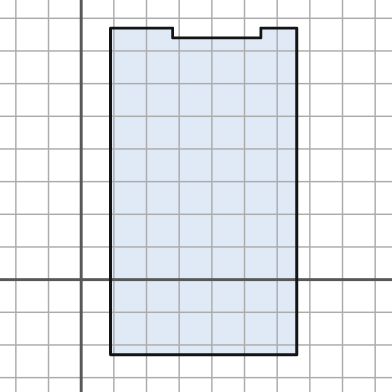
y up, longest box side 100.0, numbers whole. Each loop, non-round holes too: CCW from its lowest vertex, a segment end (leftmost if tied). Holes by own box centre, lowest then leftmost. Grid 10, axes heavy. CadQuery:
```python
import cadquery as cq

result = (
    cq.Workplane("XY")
    .moveTo(9.0, -23.0)
    .lineTo(66.0, -23.0)
    .lineTo(66.0, 77.0)
    .lineTo(55.0, 77.0)
    .lineTo(55.0, 74.0)
    .lineTo(28.0, 74.0)
    .lineTo(28.0, 77.0)
    .lineTo(9.0, 77.0)
    .close()
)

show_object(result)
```